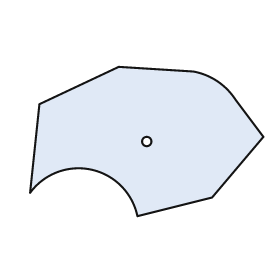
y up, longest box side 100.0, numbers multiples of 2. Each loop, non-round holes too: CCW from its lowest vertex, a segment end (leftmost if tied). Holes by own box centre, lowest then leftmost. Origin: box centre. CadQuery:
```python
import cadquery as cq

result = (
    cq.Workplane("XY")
    .moveTo(-4.0, -32.0)
    .lineTo(28.0, -24.0)
    .lineTo(50.0, 2.0)
    .lineTo(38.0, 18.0)
    .threePointArc((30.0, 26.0), (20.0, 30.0))
    .lineTo(-12.0, 32.0)
    .lineTo(-46.0, 16.0)
    .lineTo(-50.0, -22.0)
    .threePointArc((-24.0, -12.0), (-4.0, -32.0))
    .close()
    .moveTo(0.0, 0.0)
    .circle(2.0)
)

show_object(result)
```